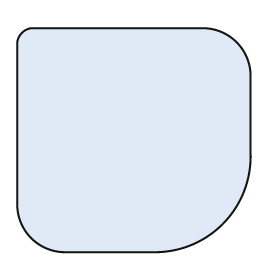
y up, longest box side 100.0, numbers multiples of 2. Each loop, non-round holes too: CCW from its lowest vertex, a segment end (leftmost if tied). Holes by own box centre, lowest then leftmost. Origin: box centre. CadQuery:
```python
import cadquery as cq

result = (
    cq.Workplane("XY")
    .moveTo(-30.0, -48.0)
    .lineTo(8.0, -48.0)
    .threePointArc((38.0, -36.0), (50.0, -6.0))
    .lineTo(50.0, 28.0)
    .threePointArc((44.0, 42.0), (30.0, 48.0))
    .lineTo(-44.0, 48.0)
    .threePointArc((-48.0, 46.0), (-50.0, 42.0))
    .lineTo(-50.0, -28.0)
    .threePointArc((-44.0, -42.0), (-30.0, -48.0))
    .close()
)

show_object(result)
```